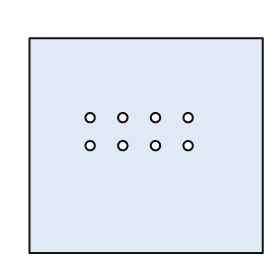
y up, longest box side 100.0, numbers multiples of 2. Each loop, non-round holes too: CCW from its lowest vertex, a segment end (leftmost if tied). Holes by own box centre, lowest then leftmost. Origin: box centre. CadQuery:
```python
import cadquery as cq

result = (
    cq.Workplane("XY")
    .moveTo(-50.0, -46.0)
    .lineTo(50.0, -46.0)
    .lineTo(50.0, 46.0)
    .lineTo(-50.0, 46.0)
    .close()
    .moveTo(-24.0, 0.0)
    .circle(2.0)
    .moveTo(-10.0, 0.0)
    .circle(2.0)
    .moveTo(4.0, 0.0)
    .circle(2.0)
    .moveTo(18.0, 0.0)
    .circle(2.0)
    .moveTo(-24.0, 12.0)
    .circle(2.0)
    .moveTo(-10.0, 12.0)
    .circle(2.0)
    .moveTo(4.0, 12.0)
    .circle(2.0)
    .moveTo(18.0, 12.0)
    .circle(2.0)
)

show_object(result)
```